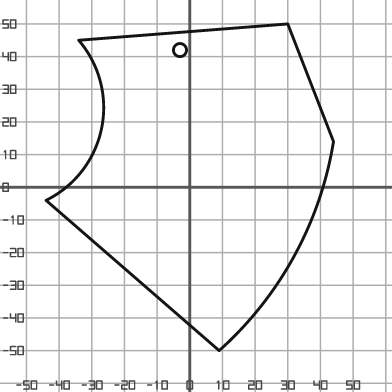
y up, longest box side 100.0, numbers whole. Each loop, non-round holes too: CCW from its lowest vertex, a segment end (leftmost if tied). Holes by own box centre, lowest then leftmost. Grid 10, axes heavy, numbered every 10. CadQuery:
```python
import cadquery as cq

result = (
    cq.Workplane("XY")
    .moveTo(9.0, -50.0)
    .threePointArc((32.0, -21.0), (44.0, 14.0))
    .lineTo(30.0, 50.0)
    .lineTo(-34.0, 45.0)
    .threePointArc((-27.0, 18.0), (-44.0, -4.0))
    .close()
    .moveTo(-3.0, 42.0)
    .circle(2.0)
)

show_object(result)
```